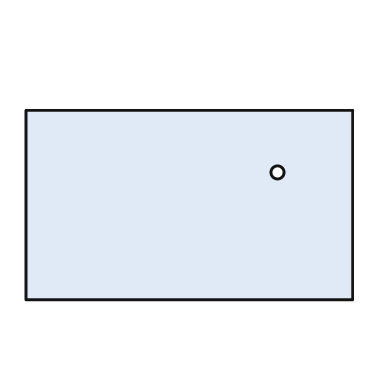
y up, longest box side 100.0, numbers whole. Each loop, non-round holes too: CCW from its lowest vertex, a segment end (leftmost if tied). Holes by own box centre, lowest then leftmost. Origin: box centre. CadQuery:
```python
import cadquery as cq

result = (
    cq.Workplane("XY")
    .moveTo(-50.0, -29.0)
    .lineTo(50.0, -29.0)
    .lineTo(50.0, 29.0)
    .lineTo(-50.0, 29.0)
    .close()
    .moveTo(27.0, 10.0)
    .circle(2.0)
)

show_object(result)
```